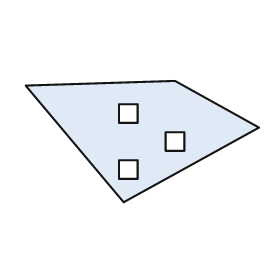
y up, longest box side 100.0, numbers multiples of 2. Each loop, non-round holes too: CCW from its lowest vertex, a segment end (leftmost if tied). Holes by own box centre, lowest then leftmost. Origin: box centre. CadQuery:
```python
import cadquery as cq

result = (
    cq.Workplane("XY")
    .moveTo(-8.0, -26.0)
    .lineTo(50.0, 6.0)
    .lineTo(14.0, 26.0)
    .lineTo(-50.0, 24.0)
    .close()
    .moveTo(-10.0, -16.0)
    .lineTo(-2.0, -16.0)
    .lineTo(-2.0, -8.0)
    .lineTo(-10.0, -8.0)
    .close()
    .moveTo(10.0, -4.0)
    .lineTo(18.0, -4.0)
    .lineTo(18.0, 4.0)
    .lineTo(10.0, 4.0)
    .close()
    .moveTo(-10.0, 8.0)
    .lineTo(-2.0, 8.0)
    .lineTo(-2.0, 16.0)
    .lineTo(-10.0, 16.0)
    .close()
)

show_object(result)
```